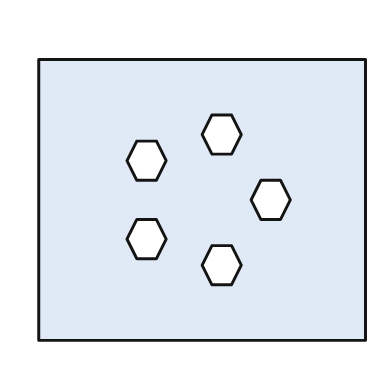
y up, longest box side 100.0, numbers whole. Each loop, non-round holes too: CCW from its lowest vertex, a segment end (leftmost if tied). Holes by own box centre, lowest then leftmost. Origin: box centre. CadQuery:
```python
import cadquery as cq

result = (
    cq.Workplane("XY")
    .moveTo(-50.0, -43.0)
    .lineTo(50.0, -43.0)
    .lineTo(50.0, 43.0)
    .lineTo(-50.0, 43.0)
    .close()
    .moveTo(3.0, -26.0)
    .lineTo(9.0, -26.0)
    .lineTo(12.0, -20.0)
    .lineTo(9.0, -14.0)
    .lineTo(3.0, -14.0)
    .lineTo(0.0, -20.0)
    .close()
    .moveTo(-20.0, -18.0)
    .lineTo(-14.0, -18.0)
    .lineTo(-11.0, -12.0)
    .lineTo(-14.0, -6.0)
    .lineTo(-20.0, -6.0)
    .lineTo(-23.0, -12.0)
    .close()
    .moveTo(18.0, -6.0)
    .lineTo(24.0, -6.0)
    .lineTo(27.0, 0.0)
    .lineTo(24.0, 6.0)
    .lineTo(18.0, 6.0)
    .lineTo(15.0, 0.0)
    .close()
    .moveTo(-20.0, 6.0)
    .lineTo(-14.0, 6.0)
    .lineTo(-11.0, 12.0)
    .lineTo(-14.0, 18.0)
    .lineTo(-20.0, 18.0)
    .lineTo(-23.0, 12.0)
    .close()
    .moveTo(3.0, 14.0)
    .lineTo(9.0, 14.0)
    .lineTo(12.0, 20.0)
    .lineTo(9.0, 26.0)
    .lineTo(3.0, 26.0)
    .lineTo(0.0, 20.0)
    .close()
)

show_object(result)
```